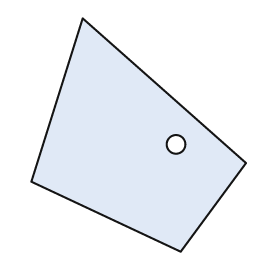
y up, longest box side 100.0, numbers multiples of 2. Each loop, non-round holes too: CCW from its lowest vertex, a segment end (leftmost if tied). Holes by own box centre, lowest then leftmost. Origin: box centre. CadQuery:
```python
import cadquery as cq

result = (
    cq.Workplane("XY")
    .moveTo(18.0, -50.0)
    .lineTo(46.0, -12.0)
    .lineTo(-24.0, 50.0)
    .lineTo(-46.0, -20.0)
    .close()
    .moveTo(16.0, -4.0)
    .circle(4.0)
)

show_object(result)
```